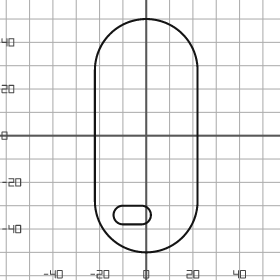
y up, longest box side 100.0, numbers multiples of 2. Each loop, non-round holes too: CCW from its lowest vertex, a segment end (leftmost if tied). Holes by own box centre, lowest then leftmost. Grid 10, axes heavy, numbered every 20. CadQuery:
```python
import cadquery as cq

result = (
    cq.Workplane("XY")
    .moveTo(-22.0, -28.0)
    .threePointArc((0.0, -50.0), (22.0, -28.0))
    .lineTo(22.0, 28.0)
    .threePointArc((0.0, 50.0), (-22.0, 28.0))
    .close()
    .moveTo(-10.0, -38.0)
    .lineTo(-2.0, -38.0)
    .threePointArc((2.0, -34.0), (-2.0, -30.0))
    .lineTo(-10.0, -30.0)
    .threePointArc((-14.0, -34.0), (-10.0, -38.0))
    .close()
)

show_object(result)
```